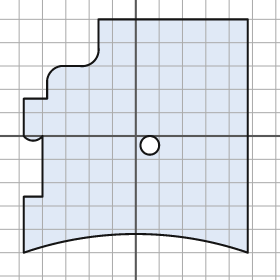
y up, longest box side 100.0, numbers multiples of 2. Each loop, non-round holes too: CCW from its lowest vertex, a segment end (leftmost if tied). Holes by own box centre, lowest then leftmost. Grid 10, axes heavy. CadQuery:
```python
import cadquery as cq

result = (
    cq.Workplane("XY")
    .moveTo(-48.0, -50.0)
    .threePointArc((0.0, -42.0), (48.0, -50.0))
    .lineTo(48.0, 50.0)
    .lineTo(-16.0, 50.0)
    .lineTo(-16.0, 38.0)
    .threePointArc((-18.0, 32.0), (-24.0, 30.0))
    .lineTo(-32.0, 30.0)
    .threePointArc((-36.0, 28.0), (-38.0, 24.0))
    .lineTo(-38.0, 16.0)
    .lineTo(-48.0, 16.0)
    .lineTo(-48.0, 0.0)
    .threePointArc((-44.0, -2.0), (-40.0, 0.0))
    .lineTo(-40.0, -26.0)
    .lineTo(-48.0, -26.0)
    .close()
    .moveTo(6.0, -4.0)
    .circle(4.0)
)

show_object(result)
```